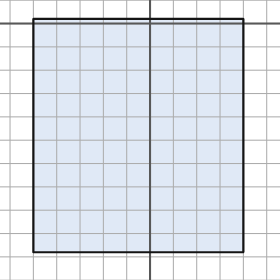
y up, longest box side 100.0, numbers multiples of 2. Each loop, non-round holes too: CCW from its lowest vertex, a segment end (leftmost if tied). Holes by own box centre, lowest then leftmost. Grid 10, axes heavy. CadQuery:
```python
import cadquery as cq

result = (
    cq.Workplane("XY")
    .moveTo(-50.0, -98.0)
    .lineTo(40.0, -98.0)
    .lineTo(40.0, 2.0)
    .lineTo(-50.0, 2.0)
    .close()
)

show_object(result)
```